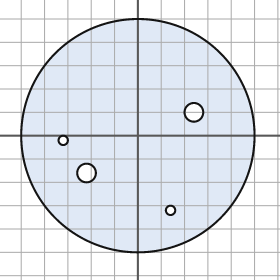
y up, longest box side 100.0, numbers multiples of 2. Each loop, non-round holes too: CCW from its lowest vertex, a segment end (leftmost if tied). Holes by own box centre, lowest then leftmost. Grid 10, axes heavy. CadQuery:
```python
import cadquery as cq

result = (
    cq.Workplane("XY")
    .moveTo(0.0, 0.0)
    .circle(50.0)
    .moveTo(14.0, -32.0)
    .circle(2.0)
    .moveTo(-22.0, -16.0)
    .circle(4.0)
    .moveTo(-32.0, -2.0)
    .circle(2.0)
    .moveTo(24.0, 10.0)
    .circle(4.0)
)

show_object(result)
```